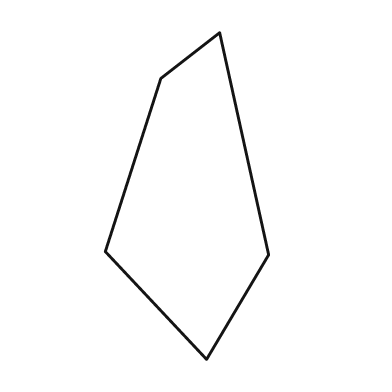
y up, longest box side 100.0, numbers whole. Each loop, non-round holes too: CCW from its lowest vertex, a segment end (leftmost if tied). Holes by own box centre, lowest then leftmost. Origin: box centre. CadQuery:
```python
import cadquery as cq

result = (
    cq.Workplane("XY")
    .moveTo(6.0, -50.0)
    .lineTo(25.0, -18.0)
    .lineTo(10.0, 50.0)
    .lineTo(-8.0, 36.0)
    .lineTo(-25.0, -17.0)
    .close()
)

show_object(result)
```